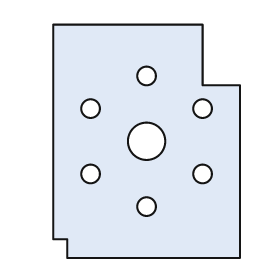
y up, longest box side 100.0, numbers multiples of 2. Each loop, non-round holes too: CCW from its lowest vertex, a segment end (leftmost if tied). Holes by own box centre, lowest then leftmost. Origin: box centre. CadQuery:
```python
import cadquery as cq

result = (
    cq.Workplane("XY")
    .moveTo(-34.0, -50.0)
    .lineTo(40.0, -50.0)
    .lineTo(40.0, 24.0)
    .lineTo(24.0, 24.0)
    .lineTo(24.0, 50.0)
    .lineTo(-40.0, 50.0)
    .lineTo(-40.0, -42.0)
    .lineTo(-34.0, -42.0)
    .close()
    .moveTo(0.0, -28.0)
    .circle(4.0)
    .moveTo(-24.0, -14.0)
    .circle(4.0)
    .moveTo(24.0, -14.0)
    .circle(4.0)
    .moveTo(0.0, 0.0)
    .circle(8.0)
    .moveTo(-24.0, 14.0)
    .circle(4.0)
    .moveTo(24.0, 14.0)
    .circle(4.0)
    .moveTo(0.0, 28.0)
    .circle(4.0)
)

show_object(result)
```